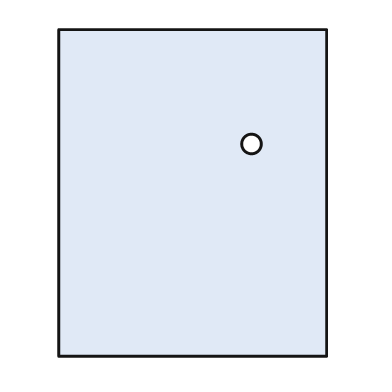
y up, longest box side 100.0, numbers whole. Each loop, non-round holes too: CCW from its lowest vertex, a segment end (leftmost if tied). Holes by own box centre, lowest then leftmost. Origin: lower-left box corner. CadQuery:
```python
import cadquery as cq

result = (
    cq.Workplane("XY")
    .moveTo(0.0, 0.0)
    .lineTo(82.0, 0.0)
    .lineTo(82.0, 100.0)
    .lineTo(0.0, 100.0)
    .close()
    .moveTo(59.0, 65.0)
    .circle(3.0)
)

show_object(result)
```